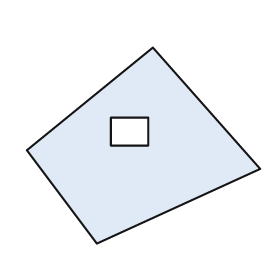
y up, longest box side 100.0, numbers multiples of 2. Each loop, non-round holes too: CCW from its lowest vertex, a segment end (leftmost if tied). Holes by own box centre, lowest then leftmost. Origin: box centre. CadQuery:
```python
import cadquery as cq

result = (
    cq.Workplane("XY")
    .moveTo(-20.0, -42.0)
    .lineTo(50.0, -10.0)
    .lineTo(4.0, 42.0)
    .lineTo(-50.0, -2.0)
    .close()
    .moveTo(-14.0, 0.0)
    .lineTo(2.0, 0.0)
    .lineTo(2.0, 12.0)
    .lineTo(-14.0, 12.0)
    .close()
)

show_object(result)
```